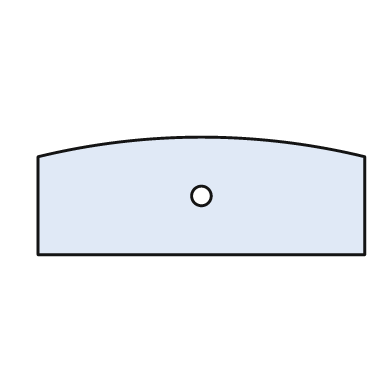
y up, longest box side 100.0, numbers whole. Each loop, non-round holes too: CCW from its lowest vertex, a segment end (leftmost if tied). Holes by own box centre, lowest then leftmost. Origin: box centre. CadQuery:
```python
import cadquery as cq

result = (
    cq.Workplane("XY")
    .moveTo(-50.0, -18.0)
    .lineTo(50.0, -18.0)
    .lineTo(50.0, 12.0)
    .threePointArc((0.0, 18.0), (-50.0, 12.0))
    .close()
    .moveTo(0.0, 0.0)
    .circle(3.0)
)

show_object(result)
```